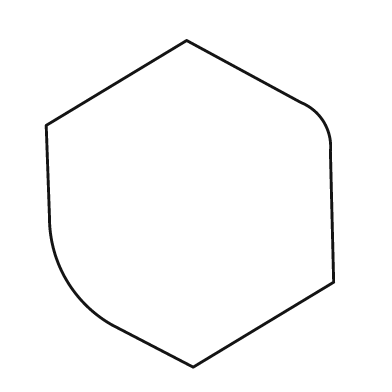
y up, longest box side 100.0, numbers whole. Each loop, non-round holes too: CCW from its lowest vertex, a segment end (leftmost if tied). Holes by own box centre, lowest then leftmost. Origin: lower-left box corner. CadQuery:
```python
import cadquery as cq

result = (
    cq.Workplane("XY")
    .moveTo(45.0, 0.0)
    .lineTo(88.0, 26.0)
    .lineTo(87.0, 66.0)
    .threePointArc((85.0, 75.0), (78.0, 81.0))
    .lineTo(43.0, 100.0)
    .lineTo(0.0, 74.0)
    .lineTo(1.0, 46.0)
    .threePointArc((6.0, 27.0), (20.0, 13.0))
    .close()
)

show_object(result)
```